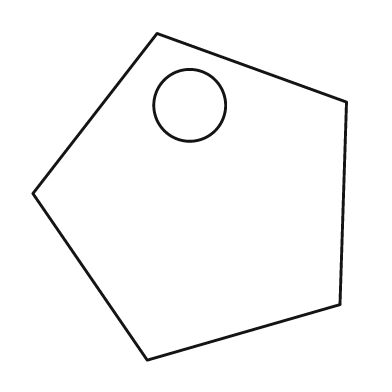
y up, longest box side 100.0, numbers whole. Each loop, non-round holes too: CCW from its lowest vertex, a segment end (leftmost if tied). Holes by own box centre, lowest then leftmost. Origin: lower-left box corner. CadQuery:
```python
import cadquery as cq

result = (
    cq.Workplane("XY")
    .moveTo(35.0, 0.0)
    .lineTo(94.0, 17.0)
    .lineTo(96.0, 79.0)
    .lineTo(38.0, 100.0)
    .lineTo(0.0, 51.0)
    .close()
    .moveTo(48.0, 78.0)
    .circle(11.0)
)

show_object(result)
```